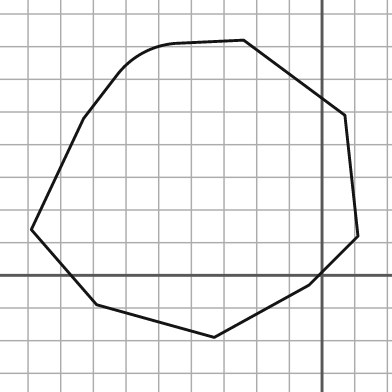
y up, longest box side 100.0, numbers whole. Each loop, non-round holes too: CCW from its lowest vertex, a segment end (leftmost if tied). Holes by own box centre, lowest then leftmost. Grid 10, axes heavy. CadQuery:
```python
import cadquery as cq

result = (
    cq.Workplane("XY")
    .moveTo(-33.0, -19.0)
    .lineTo(-4.0, -3.0)
    .lineTo(11.0, 12.0)
    .lineTo(7.0, 49.0)
    .lineTo(-24.0, 72.0)
    .lineTo(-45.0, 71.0)
    .threePointArc((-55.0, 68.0), (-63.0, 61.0))
    .lineTo(-73.0, 48.0)
    .lineTo(-89.0, 14.0)
    .lineTo(-69.0, -9.0)
    .close()
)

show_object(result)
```